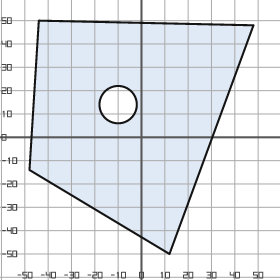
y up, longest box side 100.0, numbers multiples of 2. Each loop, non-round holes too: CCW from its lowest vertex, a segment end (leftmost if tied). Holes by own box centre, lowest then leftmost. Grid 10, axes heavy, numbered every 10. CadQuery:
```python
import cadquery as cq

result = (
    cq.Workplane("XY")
    .moveTo(12.0, -50.0)
    .lineTo(48.0, 48.0)
    .lineTo(-44.0, 50.0)
    .lineTo(-48.0, -14.0)
    .close()
    .moveTo(-10.0, 14.0)
    .circle(8.0)
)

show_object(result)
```